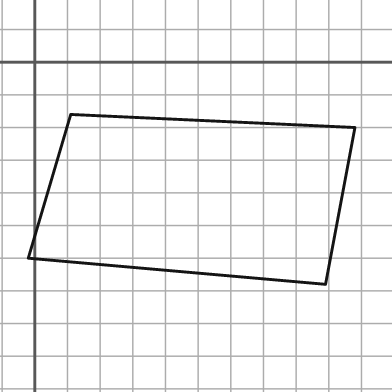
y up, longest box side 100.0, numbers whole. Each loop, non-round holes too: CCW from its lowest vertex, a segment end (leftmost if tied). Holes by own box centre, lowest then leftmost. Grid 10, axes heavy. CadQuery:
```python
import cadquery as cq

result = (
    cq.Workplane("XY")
    .moveTo(89.0, -68.0)
    .lineTo(98.0, -20.0)
    .lineTo(11.0, -16.0)
    .lineTo(-2.0, -60.0)
    .close()
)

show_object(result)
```